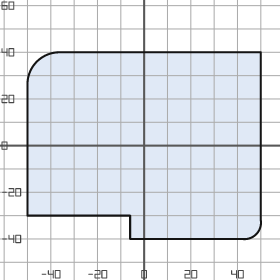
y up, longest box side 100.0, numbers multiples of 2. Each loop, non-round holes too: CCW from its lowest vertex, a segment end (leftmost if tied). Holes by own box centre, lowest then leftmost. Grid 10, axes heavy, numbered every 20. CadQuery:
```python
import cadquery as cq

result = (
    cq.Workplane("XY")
    .moveTo(-6.0, -40.0)
    .lineTo(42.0, -40.0)
    .threePointArc((48.0, -38.0), (50.0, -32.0))
    .lineTo(50.0, 40.0)
    .lineTo(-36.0, 40.0)
    .threePointArc((-46.0, 36.0), (-50.0, 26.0))
    .lineTo(-50.0, -30.0)
    .lineTo(-6.0, -30.0)
    .close()
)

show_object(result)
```